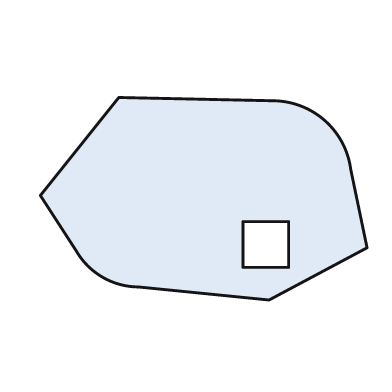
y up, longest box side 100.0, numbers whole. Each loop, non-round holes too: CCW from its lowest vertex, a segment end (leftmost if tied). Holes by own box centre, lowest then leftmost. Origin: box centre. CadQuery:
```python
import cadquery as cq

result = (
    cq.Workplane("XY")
    .moveTo(20.0, -31.0)
    .lineTo(50.0, -15.0)
    .lineTo(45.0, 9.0)
    .threePointArc((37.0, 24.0), (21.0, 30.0))
    .lineTo(-26.0, 31.0)
    .lineTo(-50.0, 1.0)
    .lineTo(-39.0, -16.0)
    .threePointArc((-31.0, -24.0), (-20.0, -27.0))
    .close()
    .moveTo(12.0, -21.0)
    .lineTo(26.0, -21.0)
    .lineTo(26.0, -7.0)
    .lineTo(12.0, -7.0)
    .close()
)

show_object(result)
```